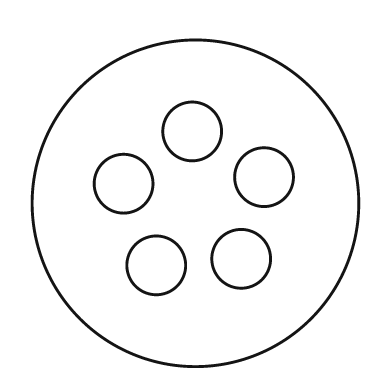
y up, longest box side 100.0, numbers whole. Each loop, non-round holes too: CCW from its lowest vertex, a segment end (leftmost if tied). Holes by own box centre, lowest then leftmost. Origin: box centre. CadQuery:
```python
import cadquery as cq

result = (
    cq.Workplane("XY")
    .moveTo(0.0, 0.0)
    .circle(50.0)
    .moveTo(-12.0, -19.0)
    .circle(9.0)
    .moveTo(14.0, -17.0)
    .circle(9.0)
    .moveTo(-22.0, 6.0)
    .circle(9.0)
    .moveTo(21.0, 8.0)
    .circle(9.0)
    .moveTo(-1.0, 22.0)
    .circle(9.0)
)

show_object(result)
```